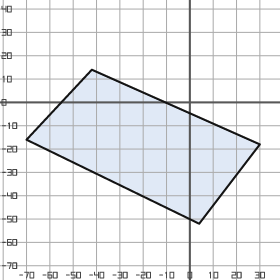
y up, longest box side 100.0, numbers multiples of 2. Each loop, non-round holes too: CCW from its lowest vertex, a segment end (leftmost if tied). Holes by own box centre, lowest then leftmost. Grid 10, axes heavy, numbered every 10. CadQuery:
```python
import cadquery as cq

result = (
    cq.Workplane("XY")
    .moveTo(4.0, -52.0)
    .lineTo(30.0, -18.0)
    .lineTo(-42.0, 14.0)
    .lineTo(-70.0, -16.0)
    .close()
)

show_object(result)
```